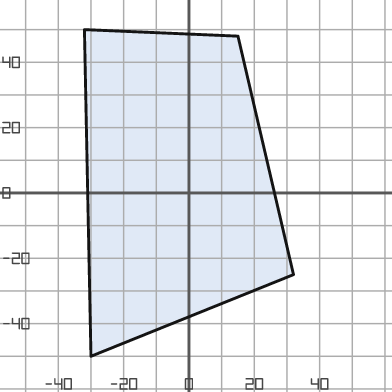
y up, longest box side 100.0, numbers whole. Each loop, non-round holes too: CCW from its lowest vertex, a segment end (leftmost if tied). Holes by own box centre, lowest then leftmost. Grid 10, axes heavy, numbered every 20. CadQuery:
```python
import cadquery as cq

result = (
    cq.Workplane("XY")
    .moveTo(-30.0, -50.0)
    .lineTo(32.0, -25.0)
    .lineTo(15.0, 48.0)
    .lineTo(-32.0, 50.0)
    .close()
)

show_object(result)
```